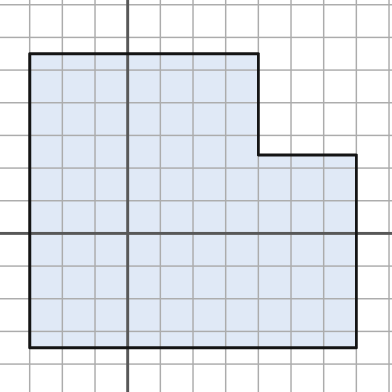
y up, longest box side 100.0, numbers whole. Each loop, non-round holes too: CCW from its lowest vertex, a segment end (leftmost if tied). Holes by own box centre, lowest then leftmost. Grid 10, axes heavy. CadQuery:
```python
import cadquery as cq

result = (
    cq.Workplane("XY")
    .moveTo(-30.0, -35.0)
    .lineTo(70.0, -35.0)
    .lineTo(70.0, 24.0)
    .lineTo(40.0, 24.0)
    .lineTo(40.0, 55.0)
    .lineTo(-30.0, 55.0)
    .close()
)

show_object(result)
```